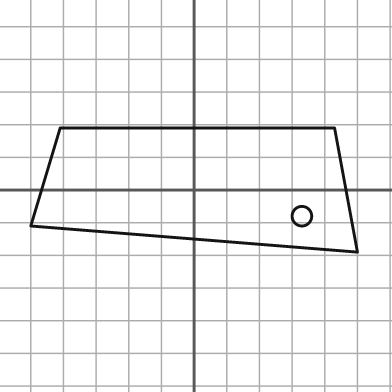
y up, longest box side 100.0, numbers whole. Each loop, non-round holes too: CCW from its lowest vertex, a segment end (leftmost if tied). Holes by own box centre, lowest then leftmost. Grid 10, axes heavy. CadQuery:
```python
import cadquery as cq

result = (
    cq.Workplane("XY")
    .moveTo(50.0, -19.0)
    .lineTo(43.0, 19.0)
    .lineTo(-41.0, 19.0)
    .lineTo(-50.0, -11.0)
    .close()
    .moveTo(33.0, -8.0)
    .circle(3.0)
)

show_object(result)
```